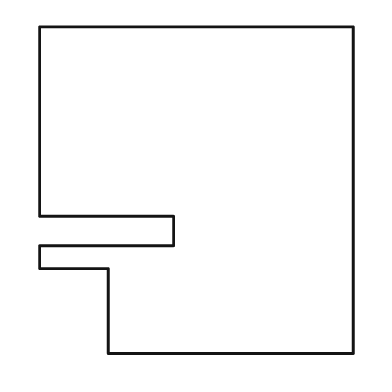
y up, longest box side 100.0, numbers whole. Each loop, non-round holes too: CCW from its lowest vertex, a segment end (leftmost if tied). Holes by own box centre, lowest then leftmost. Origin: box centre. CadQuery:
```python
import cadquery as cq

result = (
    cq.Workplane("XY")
    .moveTo(-27.0, -50.0)
    .lineTo(48.0, -50.0)
    .lineTo(48.0, 50.0)
    .lineTo(-48.0, 50.0)
    .lineTo(-48.0, -8.0)
    .lineTo(-7.0, -8.0)
    .lineTo(-7.0, -17.0)
    .lineTo(-48.0, -17.0)
    .lineTo(-48.0, -24.0)
    .lineTo(-27.0, -24.0)
    .close()
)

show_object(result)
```